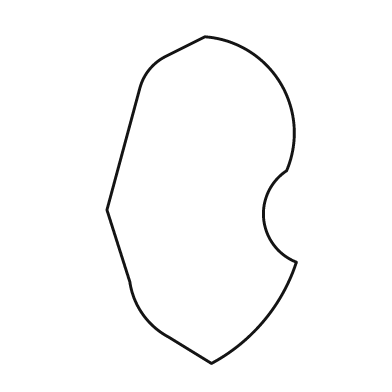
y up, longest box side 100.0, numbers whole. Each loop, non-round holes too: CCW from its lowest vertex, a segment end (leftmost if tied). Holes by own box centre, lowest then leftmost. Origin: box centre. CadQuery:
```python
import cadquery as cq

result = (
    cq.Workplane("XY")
    .moveTo(3.0, -50.0)
    .threePointArc((19.0, -37.0), (29.0, -19.0))
    .threePointArc((19.0, -6.0), (26.0, 9.0))
    .threePointArc((24.0, 36.0), (1.0, 50.0))
    .lineTo(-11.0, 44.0)
    .threePointArc((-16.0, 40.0), (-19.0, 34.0))
    .lineTo(-29.0, -3.0)
    .lineTo(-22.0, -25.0)
    .threePointArc((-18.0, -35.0), (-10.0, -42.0))
    .close()
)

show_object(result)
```